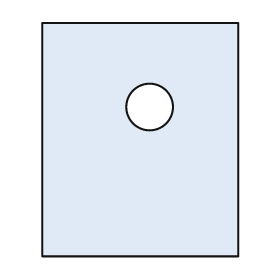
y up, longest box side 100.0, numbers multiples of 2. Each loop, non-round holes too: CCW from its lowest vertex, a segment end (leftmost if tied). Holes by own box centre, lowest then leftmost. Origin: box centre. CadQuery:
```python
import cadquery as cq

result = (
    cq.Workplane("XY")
    .moveTo(-42.0, -50.0)
    .lineTo(42.0, -50.0)
    .lineTo(42.0, 50.0)
    .lineTo(-42.0, 50.0)
    .close()
    .moveTo(4.0, 14.0)
    .circle(10.0)
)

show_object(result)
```